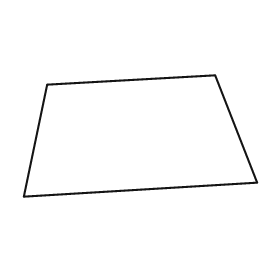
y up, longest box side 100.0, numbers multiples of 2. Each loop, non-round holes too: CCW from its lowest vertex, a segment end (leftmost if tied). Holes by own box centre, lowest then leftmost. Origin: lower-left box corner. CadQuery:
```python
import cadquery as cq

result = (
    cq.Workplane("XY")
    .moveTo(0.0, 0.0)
    .lineTo(100.0, 6.0)
    .lineTo(82.0, 52.0)
    .lineTo(10.0, 48.0)
    .close()
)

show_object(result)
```